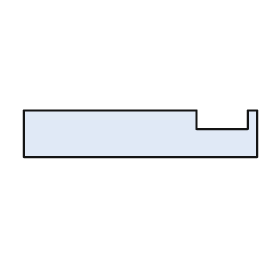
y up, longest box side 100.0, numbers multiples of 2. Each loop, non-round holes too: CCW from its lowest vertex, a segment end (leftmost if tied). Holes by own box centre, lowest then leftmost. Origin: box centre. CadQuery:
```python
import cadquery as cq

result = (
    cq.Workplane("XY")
    .moveTo(-50.0, -10.0)
    .lineTo(50.0, -10.0)
    .lineTo(50.0, 10.0)
    .lineTo(46.0, 10.0)
    .lineTo(46.0, 2.0)
    .lineTo(24.0, 2.0)
    .lineTo(24.0, 10.0)
    .lineTo(-50.0, 10.0)
    .close()
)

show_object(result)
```